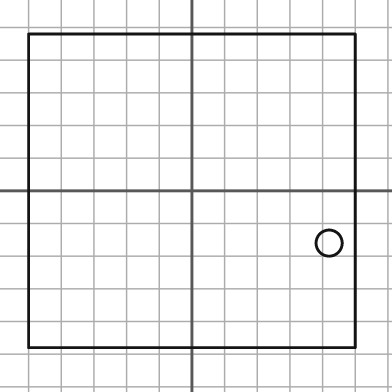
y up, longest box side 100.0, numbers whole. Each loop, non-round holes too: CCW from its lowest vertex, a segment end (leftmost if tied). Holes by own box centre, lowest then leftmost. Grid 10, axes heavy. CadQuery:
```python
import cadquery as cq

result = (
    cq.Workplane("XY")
    .moveTo(-50.0, -48.0)
    .lineTo(50.0, -48.0)
    .lineTo(50.0, 48.0)
    .lineTo(-50.0, 48.0)
    .close()
    .moveTo(42.0, -16.0)
    .circle(4.0)
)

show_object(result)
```